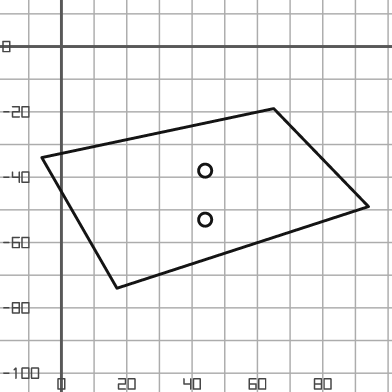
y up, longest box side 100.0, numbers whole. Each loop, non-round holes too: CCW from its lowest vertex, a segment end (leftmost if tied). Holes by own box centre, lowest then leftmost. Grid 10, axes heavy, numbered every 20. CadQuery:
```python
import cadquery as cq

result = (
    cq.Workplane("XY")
    .moveTo(17.0, -74.0)
    .lineTo(94.0, -49.0)
    .lineTo(65.0, -19.0)
    .lineTo(-6.0, -34.0)
    .close()
    .moveTo(44.0, -53.0)
    .circle(2.0)
    .moveTo(44.0, -38.0)
    .circle(2.0)
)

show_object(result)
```